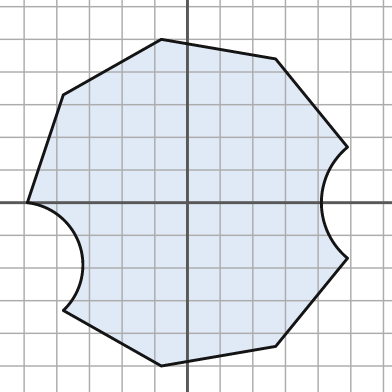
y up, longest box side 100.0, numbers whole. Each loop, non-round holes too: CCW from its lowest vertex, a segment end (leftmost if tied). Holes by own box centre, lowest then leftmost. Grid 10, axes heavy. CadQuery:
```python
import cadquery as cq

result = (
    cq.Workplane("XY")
    .moveTo(-8.0, -50.0)
    .lineTo(27.0, -44.0)
    .lineTo(49.0, -17.0)
    .threePointArc((41.0, 0.0), (49.0, 17.0))
    .lineTo(27.0, 44.0)
    .lineTo(-8.0, 50.0)
    .lineTo(-38.0, 33.0)
    .lineTo(-49.0, 0.0)
    .threePointArc((-33.0, -13.0), (-38.0, -33.0))
    .close()
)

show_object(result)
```